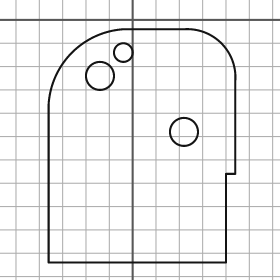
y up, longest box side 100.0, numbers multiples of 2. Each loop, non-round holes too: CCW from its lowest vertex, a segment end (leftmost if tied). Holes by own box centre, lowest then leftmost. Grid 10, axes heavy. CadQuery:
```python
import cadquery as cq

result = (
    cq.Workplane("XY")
    .moveTo(-36.0, -104.0)
    .lineTo(40.0, -104.0)
    .lineTo(40.0, -66.0)
    .lineTo(44.0, -66.0)
    .lineTo(44.0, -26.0)
    .threePointArc((38.0, -10.0), (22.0, -4.0))
    .lineTo(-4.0, -4.0)
    .threePointArc((-26.0, -14.0), (-36.0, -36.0))
    .close()
    .moveTo(22.0, -48.0)
    .circle(6.0)
    .moveTo(-14.0, -24.0)
    .circle(6.0)
    .moveTo(-4.0, -14.0)
    .circle(4.0)
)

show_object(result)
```